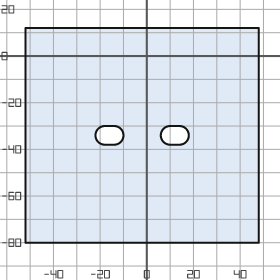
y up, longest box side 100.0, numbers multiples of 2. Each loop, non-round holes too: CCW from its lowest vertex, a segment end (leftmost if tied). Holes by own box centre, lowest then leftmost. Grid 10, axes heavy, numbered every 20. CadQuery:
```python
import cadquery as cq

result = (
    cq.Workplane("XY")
    .moveTo(-52.0, -80.0)
    .lineTo(48.0, -80.0)
    .lineTo(48.0, 12.0)
    .lineTo(-52.0, 12.0)
    .close()
    .moveTo(-18.0, -38.0)
    .lineTo(-14.0, -38.0)
    .threePointArc((-10.0, -34.0), (-14.0, -30.0))
    .lineTo(-18.0, -30.0)
    .threePointArc((-22.0, -34.0), (-18.0, -38.0))
    .close()
    .moveTo(10.0, -38.0)
    .lineTo(14.0, -38.0)
    .threePointArc((18.0, -34.0), (14.0, -30.0))
    .lineTo(10.0, -30.0)
    .threePointArc((6.0, -34.0), (10.0, -38.0))
    .close()
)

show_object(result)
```